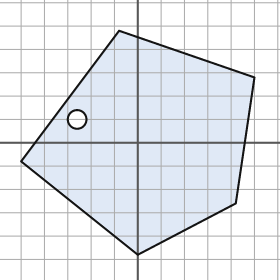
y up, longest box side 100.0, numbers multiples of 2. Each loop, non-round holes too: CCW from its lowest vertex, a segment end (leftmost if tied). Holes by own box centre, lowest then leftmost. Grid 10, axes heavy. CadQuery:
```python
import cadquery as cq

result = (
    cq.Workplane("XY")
    .moveTo(0.0, -48.0)
    .lineTo(42.0, -26.0)
    .lineTo(50.0, 28.0)
    .lineTo(-8.0, 48.0)
    .lineTo(-50.0, -8.0)
    .close()
    .moveTo(-26.0, 10.0)
    .circle(4.0)
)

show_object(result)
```